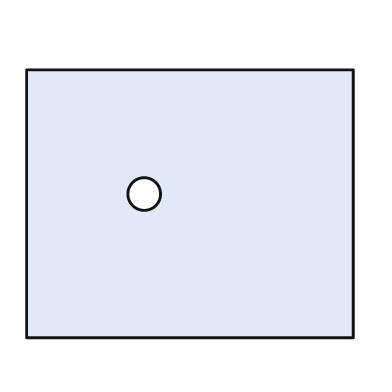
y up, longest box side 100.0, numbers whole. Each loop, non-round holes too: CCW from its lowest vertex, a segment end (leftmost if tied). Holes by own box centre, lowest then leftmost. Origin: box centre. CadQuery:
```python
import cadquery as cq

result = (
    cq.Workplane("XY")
    .moveTo(-50.0, -41.0)
    .lineTo(50.0, -41.0)
    .lineTo(50.0, 41.0)
    .lineTo(-50.0, 41.0)
    .close()
    .moveTo(-14.0, 3.0)
    .circle(5.0)
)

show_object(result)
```